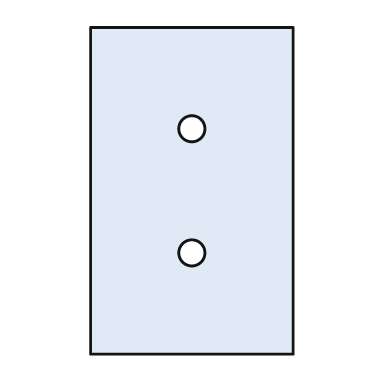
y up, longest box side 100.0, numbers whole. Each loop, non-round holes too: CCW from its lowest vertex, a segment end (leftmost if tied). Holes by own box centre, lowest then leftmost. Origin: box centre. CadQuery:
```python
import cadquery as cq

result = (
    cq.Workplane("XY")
    .moveTo(-31.0, -50.0)
    .lineTo(31.0, -50.0)
    .lineTo(31.0, 50.0)
    .lineTo(-31.0, 50.0)
    .close()
    .moveTo(0.0, -19.0)
    .circle(4.0)
    .moveTo(0.0, 19.0)
    .circle(4.0)
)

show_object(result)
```